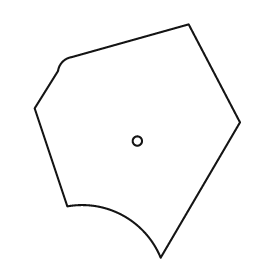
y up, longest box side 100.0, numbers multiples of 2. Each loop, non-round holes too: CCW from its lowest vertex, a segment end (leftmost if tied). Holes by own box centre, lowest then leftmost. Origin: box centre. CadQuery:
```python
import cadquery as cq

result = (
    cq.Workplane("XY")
    .moveTo(10.0, -50.0)
    .lineTo(44.0, 8.0)
    .lineTo(22.0, 50.0)
    .lineTo(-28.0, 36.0)
    .threePointArc((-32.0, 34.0), (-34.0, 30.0))
    .lineTo(-44.0, 14.0)
    .lineTo(-30.0, -28.0)
    .threePointArc((-6.0, -32.0), (10.0, -50.0))
    .close()
    .moveTo(0.0, 0.0)
    .circle(2.0)
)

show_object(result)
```